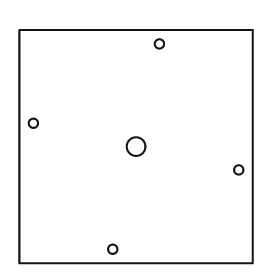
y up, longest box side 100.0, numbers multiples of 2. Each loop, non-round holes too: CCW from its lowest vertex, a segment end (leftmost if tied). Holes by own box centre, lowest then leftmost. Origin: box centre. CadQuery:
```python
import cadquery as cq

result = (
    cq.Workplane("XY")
    .moveTo(-50.0, -50.0)
    .lineTo(50.0, -50.0)
    .lineTo(50.0, 50.0)
    .lineTo(-50.0, 50.0)
    .close()
    .moveTo(-10.0, -44.0)
    .circle(2.0)
    .moveTo(44.0, -10.0)
    .circle(2.0)
    .moveTo(0.0, 0.0)
    .circle(4.0)
    .moveTo(-44.0, 10.0)
    .circle(2.0)
    .moveTo(10.0, 44.0)
    .circle(2.0)
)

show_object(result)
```